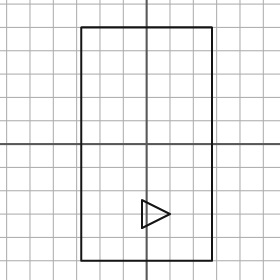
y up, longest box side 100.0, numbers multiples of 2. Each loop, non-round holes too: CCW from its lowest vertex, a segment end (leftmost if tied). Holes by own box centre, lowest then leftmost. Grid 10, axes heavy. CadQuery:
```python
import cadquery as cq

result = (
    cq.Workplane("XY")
    .moveTo(-28.0, -50.0)
    .lineTo(28.0, -50.0)
    .lineTo(28.0, 50.0)
    .lineTo(-28.0, 50.0)
    .close()
    .moveTo(-2.0, -36.0)
    .lineTo(10.0, -30.0)
    .lineTo(-2.0, -24.0)
    .close()
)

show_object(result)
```